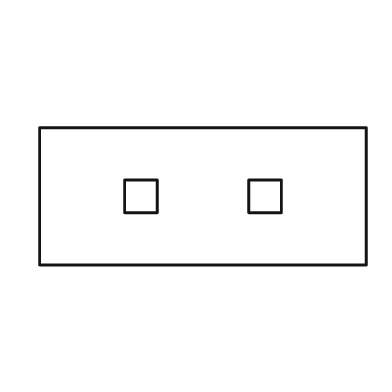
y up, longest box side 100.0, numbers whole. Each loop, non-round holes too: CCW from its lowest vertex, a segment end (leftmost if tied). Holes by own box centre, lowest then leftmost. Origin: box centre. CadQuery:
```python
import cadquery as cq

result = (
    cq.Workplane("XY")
    .moveTo(-50.0, -21.0)
    .lineTo(50.0, -21.0)
    .lineTo(50.0, 21.0)
    .lineTo(-50.0, 21.0)
    .close()
    .moveTo(-24.0, -5.0)
    .lineTo(-14.0, -5.0)
    .lineTo(-14.0, 5.0)
    .lineTo(-24.0, 5.0)
    .close()
    .moveTo(14.0, -5.0)
    .lineTo(24.0, -5.0)
    .lineTo(24.0, 5.0)
    .lineTo(14.0, 5.0)
    .close()
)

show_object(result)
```